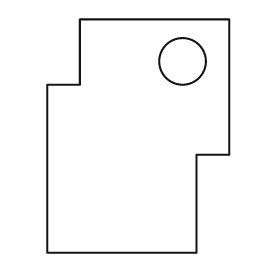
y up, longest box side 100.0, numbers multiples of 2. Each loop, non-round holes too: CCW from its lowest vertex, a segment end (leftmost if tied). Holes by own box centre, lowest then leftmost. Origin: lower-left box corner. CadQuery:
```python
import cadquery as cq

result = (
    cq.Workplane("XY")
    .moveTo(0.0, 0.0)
    .lineTo(64.0, 0.0)
    .lineTo(64.0, 42.0)
    .lineTo(78.0, 42.0)
    .lineTo(78.0, 100.0)
    .lineTo(14.0, 100.0)
    .lineTo(14.0, 72.0)
    .lineTo(0.0, 72.0)
    .close()
    .moveTo(58.0, 82.0)
    .circle(10.0)
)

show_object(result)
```